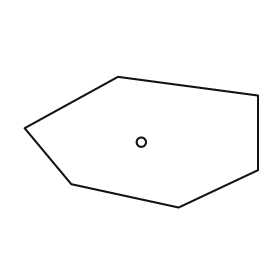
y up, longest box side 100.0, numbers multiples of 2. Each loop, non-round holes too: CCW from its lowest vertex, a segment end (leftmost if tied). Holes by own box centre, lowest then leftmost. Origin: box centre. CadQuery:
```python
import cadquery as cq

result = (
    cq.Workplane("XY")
    .moveTo(16.0, -28.0)
    .lineTo(50.0, -12.0)
    .lineTo(50.0, 20.0)
    .lineTo(-10.0, 28.0)
    .lineTo(-50.0, 6.0)
    .lineTo(-30.0, -18.0)
    .close()
    .moveTo(0.0, 0.0)
    .circle(2.0)
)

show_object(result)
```